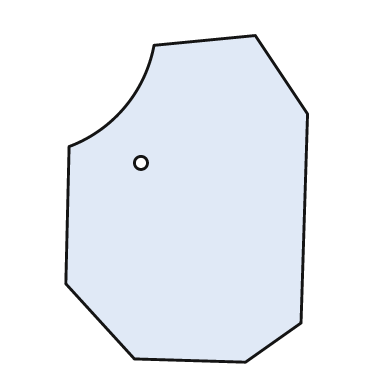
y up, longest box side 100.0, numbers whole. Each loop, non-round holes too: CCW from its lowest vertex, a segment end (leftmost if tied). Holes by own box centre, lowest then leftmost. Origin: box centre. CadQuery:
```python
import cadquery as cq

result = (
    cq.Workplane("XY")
    .moveTo(18.0, -50.0)
    .lineTo(35.0, -38.0)
    .lineTo(37.0, 26.0)
    .lineTo(21.0, 50.0)
    .lineTo(-10.0, 47.0)
    .threePointArc((-19.0, 28.0), (-36.0, 16.0))
    .lineTo(-37.0, -26.0)
    .lineTo(-16.0, -49.0)
    .close()
    .moveTo(-14.0, 11.0)
    .circle(2.0)
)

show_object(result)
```